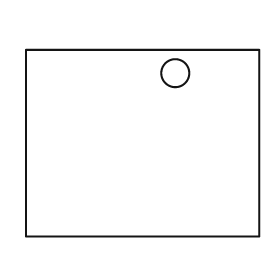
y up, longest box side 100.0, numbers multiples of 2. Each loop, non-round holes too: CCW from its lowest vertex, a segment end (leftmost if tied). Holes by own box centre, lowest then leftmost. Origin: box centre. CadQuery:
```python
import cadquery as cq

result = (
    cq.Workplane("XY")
    .moveTo(-50.0, -40.0)
    .lineTo(50.0, -40.0)
    .lineTo(50.0, 40.0)
    .lineTo(-50.0, 40.0)
    .close()
    .moveTo(14.0, 30.0)
    .circle(6.0)
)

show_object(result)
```